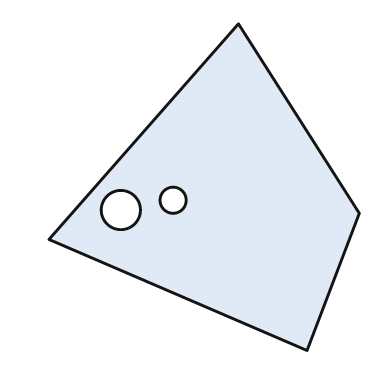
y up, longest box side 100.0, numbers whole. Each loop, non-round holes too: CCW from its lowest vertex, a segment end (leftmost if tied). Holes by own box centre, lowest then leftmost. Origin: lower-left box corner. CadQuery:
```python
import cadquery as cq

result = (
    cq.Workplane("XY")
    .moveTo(79.0, 0.0)
    .lineTo(95.0, 42.0)
    .lineTo(58.0, 100.0)
    .lineTo(0.0, 34.0)
    .close()
    .moveTo(22.0, 43.0)
    .circle(6.0)
    .moveTo(38.0, 46.0)
    .circle(4.0)
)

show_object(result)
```